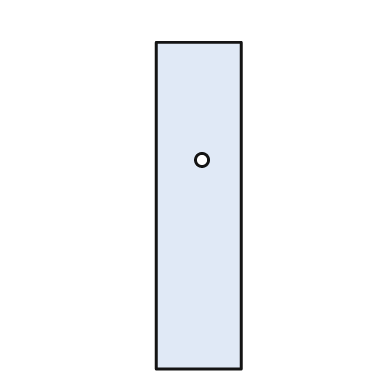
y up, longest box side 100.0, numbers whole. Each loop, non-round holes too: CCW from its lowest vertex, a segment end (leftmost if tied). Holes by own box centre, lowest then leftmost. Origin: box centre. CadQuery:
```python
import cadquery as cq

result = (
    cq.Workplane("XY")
    .moveTo(-13.0, -50.0)
    .lineTo(13.0, -50.0)
    .lineTo(13.0, 50.0)
    .lineTo(-13.0, 50.0)
    .close()
    .moveTo(1.0, 14.0)
    .circle(2.0)
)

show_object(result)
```